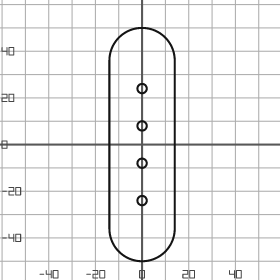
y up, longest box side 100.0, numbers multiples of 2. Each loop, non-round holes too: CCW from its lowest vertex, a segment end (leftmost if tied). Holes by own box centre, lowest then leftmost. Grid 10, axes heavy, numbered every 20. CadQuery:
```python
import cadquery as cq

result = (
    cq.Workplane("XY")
    .moveTo(-14.0, -36.0)
    .threePointArc((0.0, -50.0), (14.0, -36.0))
    .lineTo(14.0, 36.0)
    .threePointArc((0.0, 50.0), (-14.0, 36.0))
    .close()
    .moveTo(0.0, -24.0)
    .circle(2.0)
    .moveTo(0.0, -8.0)
    .circle(2.0)
    .moveTo(0.0, 8.0)
    .circle(2.0)
    .moveTo(0.0, 24.0)
    .circle(2.0)
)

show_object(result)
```